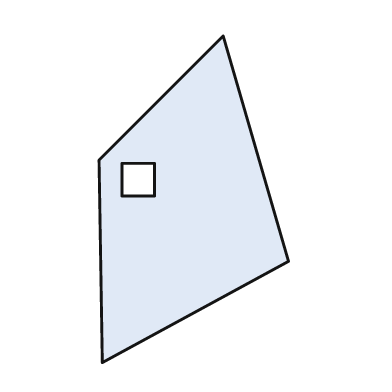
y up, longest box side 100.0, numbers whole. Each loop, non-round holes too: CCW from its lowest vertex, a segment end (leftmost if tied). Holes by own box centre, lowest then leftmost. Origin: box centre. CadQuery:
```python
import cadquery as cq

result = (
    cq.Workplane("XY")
    .moveTo(-28.0, -50.0)
    .lineTo(29.0, -19.0)
    .lineTo(9.0, 50.0)
    .lineTo(-29.0, 12.0)
    .close()
    .moveTo(-22.0, 1.0)
    .lineTo(-12.0, 1.0)
    .lineTo(-12.0, 11.0)
    .lineTo(-22.0, 11.0)
    .close()
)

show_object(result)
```